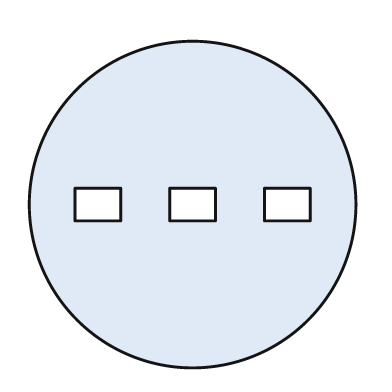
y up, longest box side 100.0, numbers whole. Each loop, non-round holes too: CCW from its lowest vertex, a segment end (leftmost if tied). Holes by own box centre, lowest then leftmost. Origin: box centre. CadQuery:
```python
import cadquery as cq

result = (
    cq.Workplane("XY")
    .moveTo(0.0, 0.0)
    .circle(50.0)
    .moveTo(-36.0, -5.0)
    .lineTo(-22.0, -5.0)
    .lineTo(-22.0, 5.0)
    .lineTo(-36.0, 5.0)
    .close()
    .moveTo(-7.0, -5.0)
    .lineTo(7.0, -5.0)
    .lineTo(7.0, 5.0)
    .lineTo(-7.0, 5.0)
    .close()
    .moveTo(22.0, -5.0)
    .lineTo(36.0, -5.0)
    .lineTo(36.0, 5.0)
    .lineTo(22.0, 5.0)
    .close()
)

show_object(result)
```